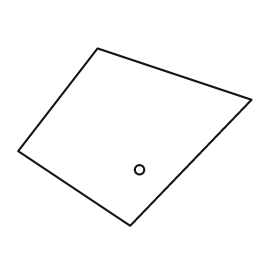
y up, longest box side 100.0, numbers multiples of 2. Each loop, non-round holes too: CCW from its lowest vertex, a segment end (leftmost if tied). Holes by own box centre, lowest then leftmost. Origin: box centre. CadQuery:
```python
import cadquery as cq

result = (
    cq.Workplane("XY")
    .moveTo(-2.0, -38.0)
    .lineTo(50.0, 16.0)
    .lineTo(-16.0, 38.0)
    .lineTo(-50.0, -6.0)
    .close()
    .moveTo(2.0, -14.0)
    .circle(2.0)
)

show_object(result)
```